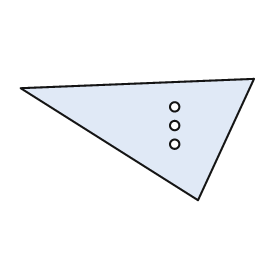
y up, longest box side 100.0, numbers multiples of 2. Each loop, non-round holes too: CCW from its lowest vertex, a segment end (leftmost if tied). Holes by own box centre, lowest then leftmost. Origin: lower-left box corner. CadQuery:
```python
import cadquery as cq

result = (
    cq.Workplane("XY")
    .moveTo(76.0, 0.0)
    .lineTo(100.0, 52.0)
    .lineTo(0.0, 48.0)
    .close()
    .moveTo(66.0, 24.0)
    .circle(2.0)
    .moveTo(66.0, 32.0)
    .circle(2.0)
    .moveTo(66.0, 40.0)
    .circle(2.0)
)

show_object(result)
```